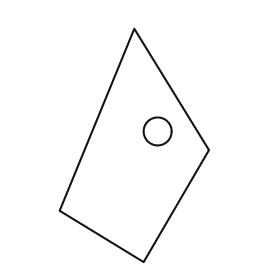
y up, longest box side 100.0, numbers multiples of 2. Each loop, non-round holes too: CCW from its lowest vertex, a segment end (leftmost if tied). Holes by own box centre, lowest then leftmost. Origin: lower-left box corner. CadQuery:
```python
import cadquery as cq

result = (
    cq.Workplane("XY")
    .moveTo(36.0, 0.0)
    .lineTo(64.0, 48.0)
    .lineTo(32.0, 100.0)
    .lineTo(0.0, 22.0)
    .close()
    .moveTo(42.0, 56.0)
    .circle(6.0)
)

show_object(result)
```